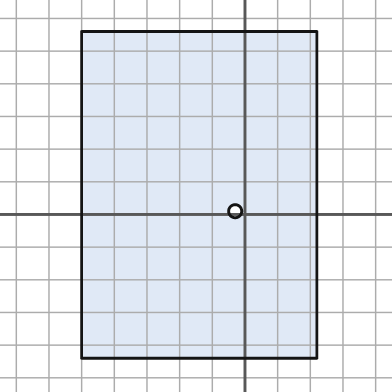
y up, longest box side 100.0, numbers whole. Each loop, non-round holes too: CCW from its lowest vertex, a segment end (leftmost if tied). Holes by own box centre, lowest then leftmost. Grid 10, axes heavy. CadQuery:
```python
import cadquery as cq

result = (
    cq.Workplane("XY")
    .moveTo(-50.0, -44.0)
    .lineTo(22.0, -44.0)
    .lineTo(22.0, 56.0)
    .lineTo(-50.0, 56.0)
    .close()
    .moveTo(-3.0, 1.0)
    .circle(2.0)
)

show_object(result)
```